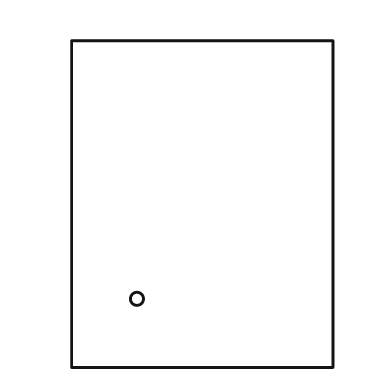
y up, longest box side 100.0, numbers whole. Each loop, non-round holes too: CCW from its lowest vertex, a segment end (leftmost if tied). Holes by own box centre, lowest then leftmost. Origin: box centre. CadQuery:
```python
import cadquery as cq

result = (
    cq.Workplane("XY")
    .moveTo(-40.0, -50.0)
    .lineTo(40.0, -50.0)
    .lineTo(40.0, 50.0)
    .lineTo(-40.0, 50.0)
    .close()
    .moveTo(-20.0, -29.0)
    .circle(2.0)
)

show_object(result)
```